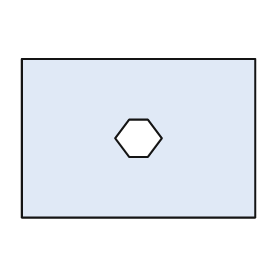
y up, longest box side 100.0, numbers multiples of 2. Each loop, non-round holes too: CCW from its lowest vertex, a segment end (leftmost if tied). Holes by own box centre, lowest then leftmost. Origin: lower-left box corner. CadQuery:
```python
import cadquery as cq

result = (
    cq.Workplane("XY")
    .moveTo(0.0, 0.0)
    .lineTo(100.0, 0.0)
    .lineTo(100.0, 68.0)
    .lineTo(0.0, 68.0)
    .close()
    .moveTo(46.0, 26.0)
    .lineTo(54.0, 26.0)
    .lineTo(60.0, 34.0)
    .lineTo(54.0, 42.0)
    .lineTo(46.0, 42.0)
    .lineTo(40.0, 34.0)
    .close()
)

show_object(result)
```